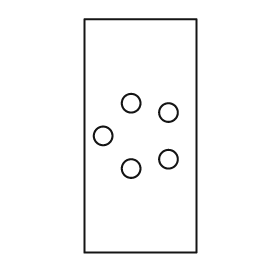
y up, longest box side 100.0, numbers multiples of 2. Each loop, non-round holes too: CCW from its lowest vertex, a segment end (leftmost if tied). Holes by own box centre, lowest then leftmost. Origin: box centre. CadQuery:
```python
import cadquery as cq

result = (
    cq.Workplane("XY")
    .moveTo(-24.0, -50.0)
    .lineTo(24.0, -50.0)
    .lineTo(24.0, 50.0)
    .lineTo(-24.0, 50.0)
    .close()
    .moveTo(-4.0, -14.0)
    .circle(4.0)
    .moveTo(12.0, -10.0)
    .circle(4.0)
    .moveTo(-16.0, 0.0)
    .circle(4.0)
    .moveTo(12.0, 10.0)
    .circle(4.0)
    .moveTo(-4.0, 14.0)
    .circle(4.0)
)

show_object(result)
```